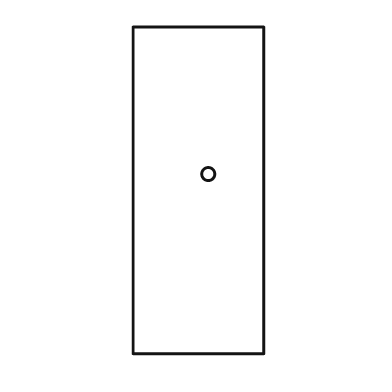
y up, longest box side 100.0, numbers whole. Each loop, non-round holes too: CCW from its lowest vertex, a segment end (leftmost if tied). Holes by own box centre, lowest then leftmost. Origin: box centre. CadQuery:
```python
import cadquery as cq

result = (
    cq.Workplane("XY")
    .moveTo(-20.0, -50.0)
    .lineTo(20.0, -50.0)
    .lineTo(20.0, 50.0)
    .lineTo(-20.0, 50.0)
    .close()
    .moveTo(3.0, 5.0)
    .circle(2.0)
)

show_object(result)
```